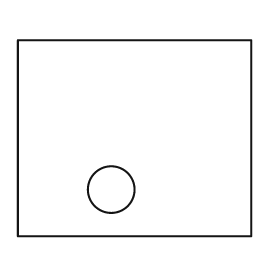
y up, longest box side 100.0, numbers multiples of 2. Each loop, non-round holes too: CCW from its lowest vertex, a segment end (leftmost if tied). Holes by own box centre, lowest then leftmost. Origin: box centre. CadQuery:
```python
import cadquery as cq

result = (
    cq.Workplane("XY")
    .moveTo(-50.0, -42.0)
    .lineTo(50.0, -42.0)
    .lineTo(50.0, 42.0)
    .lineTo(-50.0, 42.0)
    .close()
    .moveTo(-10.0, -22.0)
    .circle(10.0)
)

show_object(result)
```